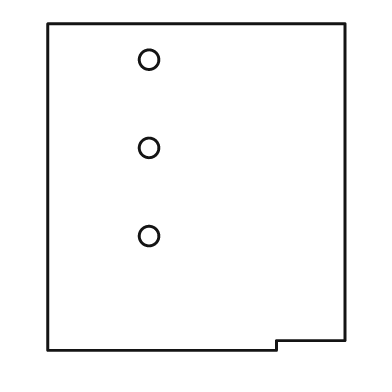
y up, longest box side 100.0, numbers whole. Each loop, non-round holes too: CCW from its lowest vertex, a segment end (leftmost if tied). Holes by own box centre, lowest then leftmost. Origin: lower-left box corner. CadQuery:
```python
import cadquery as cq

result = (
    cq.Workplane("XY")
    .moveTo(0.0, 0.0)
    .lineTo(70.0, 0.0)
    .lineTo(70.0, 3.0)
    .lineTo(91.0, 3.0)
    .lineTo(91.0, 100.0)
    .lineTo(0.0, 100.0)
    .close()
    .moveTo(31.0, 35.0)
    .circle(3.0)
    .moveTo(31.0, 62.0)
    .circle(3.0)
    .moveTo(31.0, 89.0)
    .circle(3.0)
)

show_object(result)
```